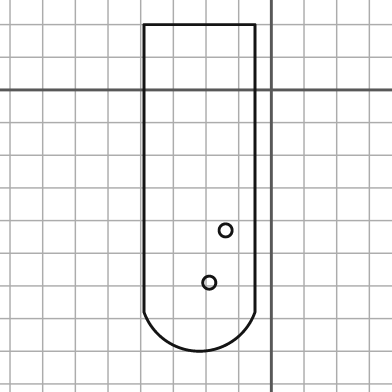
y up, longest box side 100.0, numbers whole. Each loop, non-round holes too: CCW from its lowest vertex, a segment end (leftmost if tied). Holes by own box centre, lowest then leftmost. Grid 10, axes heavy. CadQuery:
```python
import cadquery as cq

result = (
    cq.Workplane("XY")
    .moveTo(-39.0, -68.0)
    .threePointArc((-22.0, -80.0), (-5.0, -68.0))
    .lineTo(-5.0, 20.0)
    .lineTo(-39.0, 20.0)
    .close()
    .moveTo(-19.0, -59.0)
    .circle(2.0)
    .moveTo(-14.0, -43.0)
    .circle(2.0)
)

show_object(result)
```